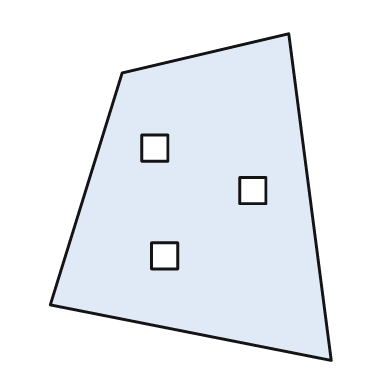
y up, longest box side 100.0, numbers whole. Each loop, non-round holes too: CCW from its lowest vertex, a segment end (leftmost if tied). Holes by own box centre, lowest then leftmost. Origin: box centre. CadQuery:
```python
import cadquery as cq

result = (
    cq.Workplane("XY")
    .moveTo(43.0, -50.0)
    .lineTo(30.0, 50.0)
    .lineTo(-21.0, 38.0)
    .lineTo(-43.0, -33.0)
    .close()
    .moveTo(-12.0, -22.0)
    .lineTo(-4.0, -22.0)
    .lineTo(-4.0, -14.0)
    .lineTo(-12.0, -14.0)
    .close()
    .moveTo(15.0, -2.0)
    .lineTo(23.0, -2.0)
    .lineTo(23.0, 6.0)
    .lineTo(15.0, 6.0)
    .close()
    .moveTo(-15.0, 11.0)
    .lineTo(-7.0, 11.0)
    .lineTo(-7.0, 19.0)
    .lineTo(-15.0, 19.0)
    .close()
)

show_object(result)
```